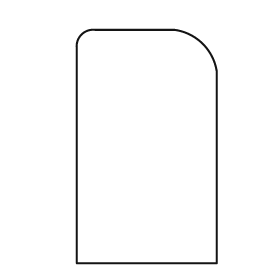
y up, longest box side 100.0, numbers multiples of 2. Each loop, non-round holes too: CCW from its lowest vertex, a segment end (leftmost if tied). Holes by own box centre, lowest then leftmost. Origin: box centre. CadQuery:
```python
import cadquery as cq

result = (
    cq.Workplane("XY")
    .moveTo(-30.0, -50.0)
    .lineTo(30.0, -50.0)
    .lineTo(30.0, 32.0)
    .threePointArc((24.0, 44.0), (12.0, 50.0))
    .lineTo(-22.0, 50.0)
    .threePointArc((-28.0, 48.0), (-30.0, 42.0))
    .close()
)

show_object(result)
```